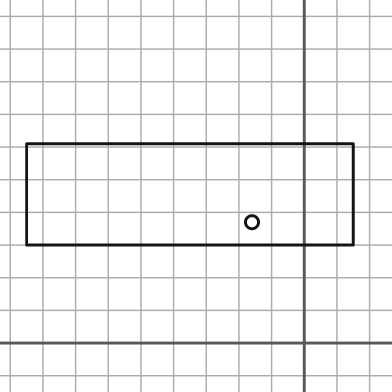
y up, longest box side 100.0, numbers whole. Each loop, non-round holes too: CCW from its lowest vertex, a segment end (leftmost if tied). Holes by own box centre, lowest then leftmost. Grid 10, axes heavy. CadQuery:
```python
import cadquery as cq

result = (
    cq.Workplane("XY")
    .moveTo(-85.0, 30.0)
    .lineTo(15.0, 30.0)
    .lineTo(15.0, 61.0)
    .lineTo(-85.0, 61.0)
    .close()
    .moveTo(-16.0, 37.0)
    .circle(2.0)
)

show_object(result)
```